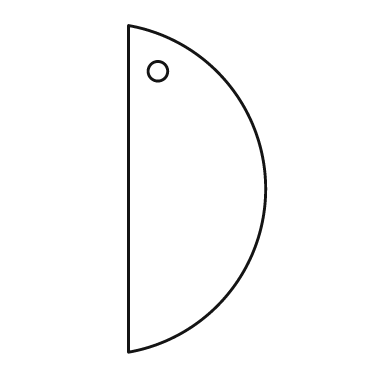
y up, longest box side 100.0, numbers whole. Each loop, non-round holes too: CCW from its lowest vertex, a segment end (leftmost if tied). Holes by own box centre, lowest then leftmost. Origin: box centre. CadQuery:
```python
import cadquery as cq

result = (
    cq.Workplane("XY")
    .moveTo(-21.0, -50.0)
    .threePointArc((21.0, 0.0), (-21.0, 50.0))
    .close()
    .moveTo(-12.0, 36.0)
    .circle(3.0)
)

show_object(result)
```